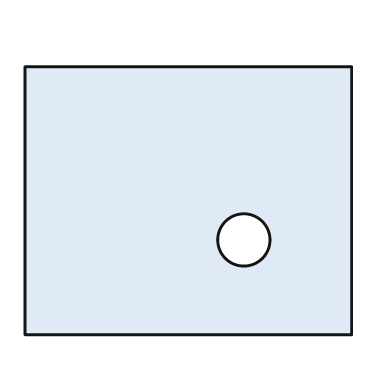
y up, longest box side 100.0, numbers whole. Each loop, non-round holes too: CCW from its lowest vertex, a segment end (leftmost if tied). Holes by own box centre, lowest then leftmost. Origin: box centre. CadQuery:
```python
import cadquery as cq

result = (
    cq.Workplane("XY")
    .moveTo(-50.0, -41.0)
    .lineTo(50.0, -41.0)
    .lineTo(50.0, 41.0)
    .lineTo(-50.0, 41.0)
    .close()
    .moveTo(17.0, -12.0)
    .circle(8.0)
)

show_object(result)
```